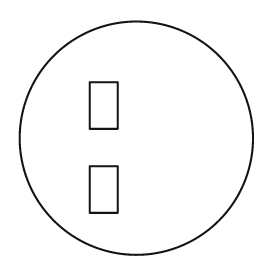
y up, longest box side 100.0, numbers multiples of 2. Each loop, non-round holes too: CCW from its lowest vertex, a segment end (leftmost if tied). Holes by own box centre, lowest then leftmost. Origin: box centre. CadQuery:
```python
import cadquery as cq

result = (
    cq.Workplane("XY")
    .moveTo(0.0, 0.0)
    .circle(50.0)
    .moveTo(-20.0, -32.0)
    .lineTo(-8.0, -32.0)
    .lineTo(-8.0, -12.0)
    .lineTo(-20.0, -12.0)
    .close()
    .moveTo(-20.0, 4.0)
    .lineTo(-8.0, 4.0)
    .lineTo(-8.0, 24.0)
    .lineTo(-20.0, 24.0)
    .close()
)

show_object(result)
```